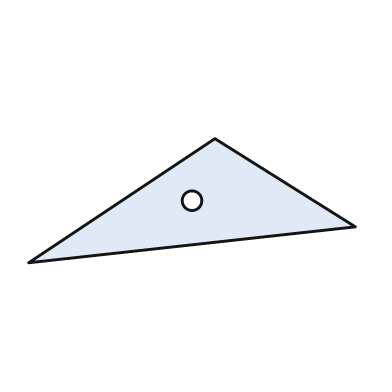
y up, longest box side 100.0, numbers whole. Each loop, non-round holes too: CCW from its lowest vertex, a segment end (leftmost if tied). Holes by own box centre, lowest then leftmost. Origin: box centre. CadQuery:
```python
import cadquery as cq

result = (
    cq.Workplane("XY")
    .moveTo(-50.0, -19.0)
    .lineTo(50.0, -8.0)
    .lineTo(7.0, 19.0)
    .close()
    .moveTo(0.0, 0.0)
    .circle(3.0)
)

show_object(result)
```